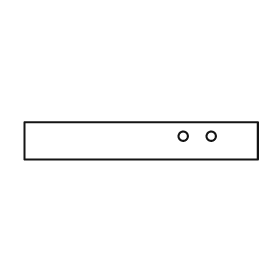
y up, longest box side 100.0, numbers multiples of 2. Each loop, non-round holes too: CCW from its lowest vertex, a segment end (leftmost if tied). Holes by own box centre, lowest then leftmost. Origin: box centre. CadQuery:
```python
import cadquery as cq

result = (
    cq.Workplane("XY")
    .moveTo(-50.0, -8.0)
    .lineTo(50.0, -8.0)
    .lineTo(50.0, 8.0)
    .lineTo(-50.0, 8.0)
    .close()
    .moveTo(18.0, 2.0)
    .circle(2.0)
    .moveTo(30.0, 2.0)
    .circle(2.0)
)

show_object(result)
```